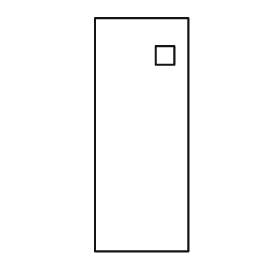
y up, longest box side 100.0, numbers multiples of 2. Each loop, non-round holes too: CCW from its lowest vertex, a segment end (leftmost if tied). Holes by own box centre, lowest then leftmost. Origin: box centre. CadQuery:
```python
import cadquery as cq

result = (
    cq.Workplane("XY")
    .moveTo(-20.0, -50.0)
    .lineTo(20.0, -50.0)
    .lineTo(20.0, 50.0)
    .lineTo(-20.0, 50.0)
    .close()
    .moveTo(6.0, 30.0)
    .lineTo(14.0, 30.0)
    .lineTo(14.0, 38.0)
    .lineTo(6.0, 38.0)
    .close()
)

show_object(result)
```